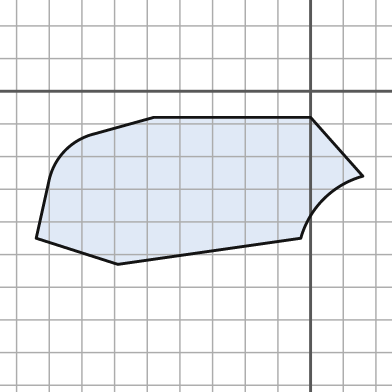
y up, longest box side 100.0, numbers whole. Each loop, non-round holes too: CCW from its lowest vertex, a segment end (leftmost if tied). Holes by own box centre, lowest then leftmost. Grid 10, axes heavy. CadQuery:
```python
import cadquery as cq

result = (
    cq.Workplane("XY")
    .moveTo(-59.0, -53.0)
    .lineTo(-3.0, -45.0)
    .threePointArc((4.0, -33.0), (16.0, -26.0))
    .lineTo(0.0, -8.0)
    .lineTo(-48.0, -8.0)
    .lineTo(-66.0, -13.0)
    .threePointArc((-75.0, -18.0), (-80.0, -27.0))
    .lineTo(-84.0, -45.0)
    .close()
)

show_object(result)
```